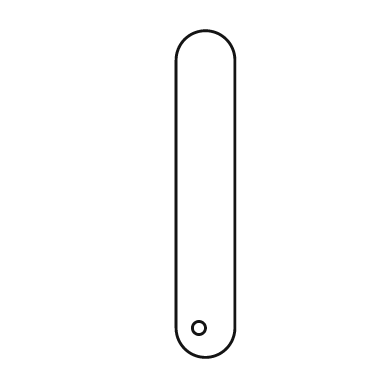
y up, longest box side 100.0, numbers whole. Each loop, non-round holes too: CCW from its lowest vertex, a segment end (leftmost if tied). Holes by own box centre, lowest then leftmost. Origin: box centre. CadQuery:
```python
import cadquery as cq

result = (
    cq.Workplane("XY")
    .moveTo(-9.0, -41.0)
    .threePointArc((0.0, -50.0), (9.0, -41.0))
    .lineTo(9.0, 41.0)
    .threePointArc((0.0, 50.0), (-9.0, 41.0))
    .close()
    .moveTo(-2.0, -41.0)
    .circle(2.0)
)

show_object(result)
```